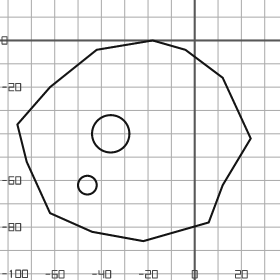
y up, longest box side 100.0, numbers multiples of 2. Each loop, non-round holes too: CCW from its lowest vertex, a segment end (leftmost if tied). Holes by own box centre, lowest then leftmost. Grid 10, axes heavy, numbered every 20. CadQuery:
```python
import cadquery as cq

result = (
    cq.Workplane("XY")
    .moveTo(-22.0, -86.0)
    .lineTo(6.0, -78.0)
    .lineTo(12.0, -62.0)
    .lineTo(24.0, -42.0)
    .lineTo(12.0, -16.0)
    .lineTo(-4.0, -4.0)
    .lineTo(-18.0, 0.0)
    .lineTo(-42.0, -4.0)
    .lineTo(-62.0, -20.0)
    .lineTo(-76.0, -36.0)
    .lineTo(-72.0, -52.0)
    .lineTo(-62.0, -74.0)
    .lineTo(-44.0, -82.0)
    .close()
    .moveTo(-46.0, -62.0)
    .circle(4.0)
    .moveTo(-36.0, -40.0)
    .circle(8.0)
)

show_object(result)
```